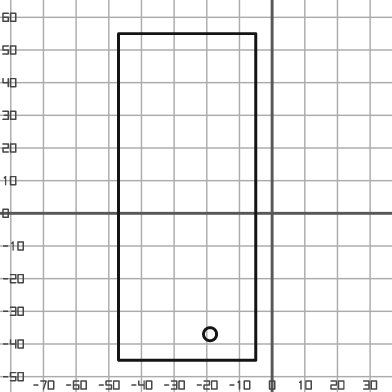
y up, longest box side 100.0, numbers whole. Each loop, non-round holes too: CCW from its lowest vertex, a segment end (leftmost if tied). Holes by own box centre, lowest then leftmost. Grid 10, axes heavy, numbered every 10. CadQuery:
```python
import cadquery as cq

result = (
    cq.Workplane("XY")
    .moveTo(-47.0, -45.0)
    .lineTo(-5.0, -45.0)
    .lineTo(-5.0, 55.0)
    .lineTo(-47.0, 55.0)
    .close()
    .moveTo(-19.0, -37.0)
    .circle(2.0)
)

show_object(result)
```